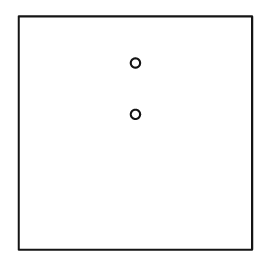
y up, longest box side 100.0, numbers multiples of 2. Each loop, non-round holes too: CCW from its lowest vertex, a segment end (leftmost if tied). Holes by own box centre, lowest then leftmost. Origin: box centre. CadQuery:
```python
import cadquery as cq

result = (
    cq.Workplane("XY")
    .moveTo(-50.0, -50.0)
    .lineTo(50.0, -50.0)
    .lineTo(50.0, 50.0)
    .lineTo(-50.0, 50.0)
    .close()
    .moveTo(0.0, 8.0)
    .circle(2.0)
    .moveTo(0.0, 30.0)
    .circle(2.0)
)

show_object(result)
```